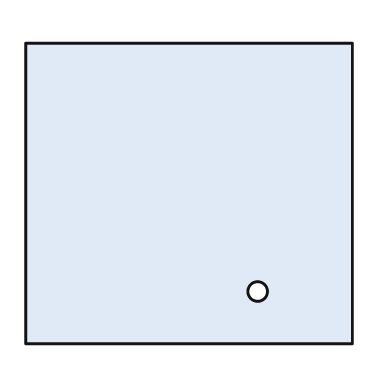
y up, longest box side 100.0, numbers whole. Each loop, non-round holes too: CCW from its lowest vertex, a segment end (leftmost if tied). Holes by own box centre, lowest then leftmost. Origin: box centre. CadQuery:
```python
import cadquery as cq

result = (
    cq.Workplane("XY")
    .moveTo(-50.0, -46.0)
    .lineTo(50.0, -46.0)
    .lineTo(50.0, 46.0)
    .lineTo(-50.0, 46.0)
    .close()
    .moveTo(21.0, -30.0)
    .circle(3.0)
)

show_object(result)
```